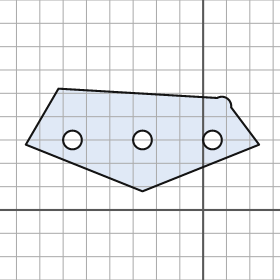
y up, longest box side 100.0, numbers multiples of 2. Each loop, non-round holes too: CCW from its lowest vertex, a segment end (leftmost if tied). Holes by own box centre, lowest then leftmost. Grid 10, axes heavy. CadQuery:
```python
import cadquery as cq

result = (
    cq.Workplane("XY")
    .moveTo(-26.0, 8.0)
    .lineTo(24.0, 28.0)
    .lineTo(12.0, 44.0)
    .threePointArc((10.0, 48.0), (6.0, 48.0))
    .lineTo(-62.0, 52.0)
    .lineTo(-76.0, 28.0)
    .close()
    .moveTo(-56.0, 30.0)
    .circle(4.0)
    .moveTo(-26.0, 30.0)
    .circle(4.0)
    .moveTo(4.0, 30.0)
    .circle(4.0)
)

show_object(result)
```